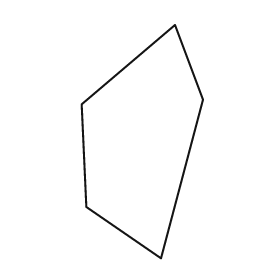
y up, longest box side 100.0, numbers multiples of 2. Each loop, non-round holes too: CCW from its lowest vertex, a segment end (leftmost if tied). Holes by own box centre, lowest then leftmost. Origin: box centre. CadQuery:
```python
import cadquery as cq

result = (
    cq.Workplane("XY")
    .moveTo(8.0, -50.0)
    .lineTo(26.0, 18.0)
    .lineTo(14.0, 50.0)
    .lineTo(-26.0, 16.0)
    .lineTo(-24.0, -28.0)
    .close()
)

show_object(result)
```